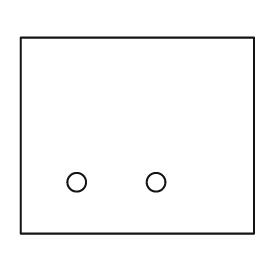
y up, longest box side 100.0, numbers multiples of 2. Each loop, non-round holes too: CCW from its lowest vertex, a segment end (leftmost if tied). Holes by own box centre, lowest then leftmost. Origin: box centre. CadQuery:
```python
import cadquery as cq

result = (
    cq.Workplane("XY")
    .moveTo(-50.0, -42.0)
    .lineTo(50.0, -42.0)
    .lineTo(50.0, 42.0)
    .lineTo(-50.0, 42.0)
    .close()
    .moveTo(-26.0, -20.0)
    .circle(4.0)
    .moveTo(8.0, -20.0)
    .circle(4.0)
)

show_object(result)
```